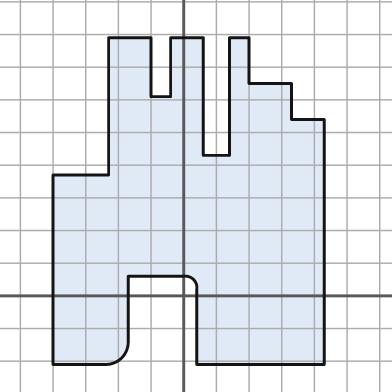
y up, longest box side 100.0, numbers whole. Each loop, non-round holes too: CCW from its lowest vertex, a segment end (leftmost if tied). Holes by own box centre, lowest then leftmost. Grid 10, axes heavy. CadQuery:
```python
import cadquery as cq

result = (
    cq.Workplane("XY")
    .moveTo(-40.0, -21.0)
    .lineTo(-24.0, -21.0)
    .threePointArc((-19.0, -19.0), (-17.0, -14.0))
    .lineTo(-17.0, 6.0)
    .lineTo(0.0, 6.0)
    .threePointArc((3.0, 5.0), (4.0, 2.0))
    .lineTo(4.0, -21.0)
    .lineTo(43.0, -21.0)
    .lineTo(43.0, 54.0)
    .lineTo(33.0, 54.0)
    .lineTo(33.0, 65.0)
    .lineTo(20.0, 65.0)
    .lineTo(20.0, 79.0)
    .lineTo(14.0, 79.0)
    .lineTo(14.0, 43.0)
    .lineTo(6.0, 43.0)
    .lineTo(6.0, 79.0)
    .lineTo(-4.0, 79.0)
    .lineTo(-4.0, 61.0)
    .lineTo(-10.0, 61.0)
    .lineTo(-10.0, 79.0)
    .lineTo(-23.0, 79.0)
    .lineTo(-23.0, 37.0)
    .lineTo(-40.0, 37.0)
    .close()
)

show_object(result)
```